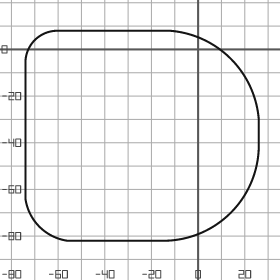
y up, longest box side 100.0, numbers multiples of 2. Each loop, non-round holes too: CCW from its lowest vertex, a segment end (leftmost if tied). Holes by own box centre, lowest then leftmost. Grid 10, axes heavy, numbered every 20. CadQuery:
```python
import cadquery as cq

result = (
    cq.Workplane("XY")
    .moveTo(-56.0, -82.0)
    .lineTo(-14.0, -82.0)
    .threePointArc((14.0, -70.0), (26.0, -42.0))
    .lineTo(26.0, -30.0)
    .threePointArc((14.0, -4.0), (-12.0, 8.0))
    .lineTo(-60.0, 8.0)
    .threePointArc((-70.0, 4.0), (-74.0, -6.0))
    .lineTo(-74.0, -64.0)
    .threePointArc((-68.0, -76.0), (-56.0, -82.0))
    .close()
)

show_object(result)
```